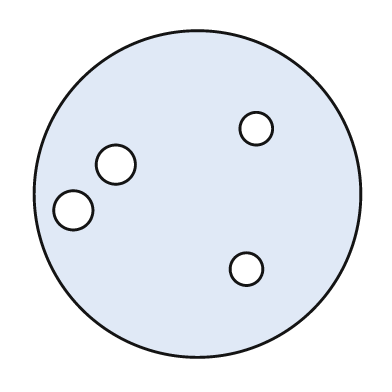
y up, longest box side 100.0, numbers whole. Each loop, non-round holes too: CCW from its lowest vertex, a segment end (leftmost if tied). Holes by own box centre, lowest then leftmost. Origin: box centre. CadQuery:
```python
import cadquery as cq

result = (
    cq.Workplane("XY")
    .moveTo(0.0, 0.0)
    .circle(50.0)
    .moveTo(15.0, -23.0)
    .circle(5.0)
    .moveTo(-38.0, -5.0)
    .circle(6.0)
    .moveTo(-25.0, 9.0)
    .circle(6.0)
    .moveTo(18.0, 20.0)
    .circle(5.0)
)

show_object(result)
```